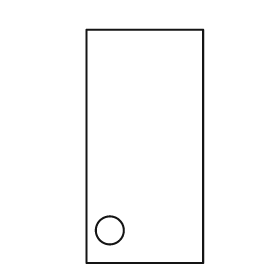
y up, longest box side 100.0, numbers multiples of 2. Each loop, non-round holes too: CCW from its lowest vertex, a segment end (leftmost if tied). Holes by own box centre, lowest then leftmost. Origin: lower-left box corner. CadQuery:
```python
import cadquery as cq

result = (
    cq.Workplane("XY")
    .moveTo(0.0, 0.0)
    .lineTo(50.0, 0.0)
    .lineTo(50.0, 100.0)
    .lineTo(0.0, 100.0)
    .close()
    .moveTo(10.0, 14.0)
    .circle(6.0)
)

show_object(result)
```